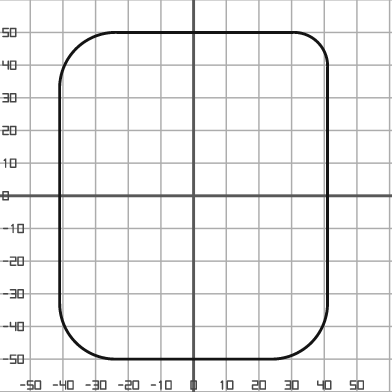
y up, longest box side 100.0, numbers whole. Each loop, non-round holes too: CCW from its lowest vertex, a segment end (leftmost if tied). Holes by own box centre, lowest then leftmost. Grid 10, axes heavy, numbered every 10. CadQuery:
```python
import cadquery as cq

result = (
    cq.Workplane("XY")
    .moveTo(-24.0, -50.0)
    .lineTo(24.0, -50.0)
    .threePointArc((36.0, -45.0), (41.0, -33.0))
    .lineTo(41.0, 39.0)
    .threePointArc((38.0, 47.0), (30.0, 50.0))
    .lineTo(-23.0, 50.0)
    .threePointArc((-36.0, 45.0), (-41.0, 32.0))
    .lineTo(-41.0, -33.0)
    .threePointArc((-36.0, -45.0), (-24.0, -50.0))
    .close()
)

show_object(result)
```